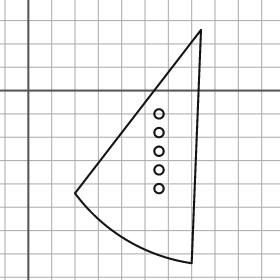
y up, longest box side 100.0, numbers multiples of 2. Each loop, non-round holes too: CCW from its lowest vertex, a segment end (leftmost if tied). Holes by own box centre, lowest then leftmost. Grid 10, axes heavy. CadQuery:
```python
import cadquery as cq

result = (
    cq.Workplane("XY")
    .moveTo(70.0, -74.0)
    .lineTo(74.0, 26.0)
    .lineTo(20.0, -44.0)
    .threePointArc((42.0, -64.0), (70.0, -74.0))
    .close()
    .moveTo(56.0, -42.0)
    .circle(2.0)
    .moveTo(56.0, -34.0)
    .circle(2.0)
    .moveTo(56.0, -26.0)
    .circle(2.0)
    .moveTo(56.0, -18.0)
    .circle(2.0)
    .moveTo(56.0, -10.0)
    .circle(2.0)
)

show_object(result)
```